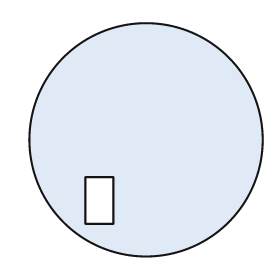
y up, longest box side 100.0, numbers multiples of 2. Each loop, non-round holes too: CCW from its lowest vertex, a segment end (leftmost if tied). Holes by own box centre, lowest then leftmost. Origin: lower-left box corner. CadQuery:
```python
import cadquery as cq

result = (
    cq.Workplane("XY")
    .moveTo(50.0, 50.0)
    .circle(50.0)
    .moveTo(24.0, 14.0)
    .lineTo(36.0, 14.0)
    .lineTo(36.0, 34.0)
    .lineTo(24.0, 34.0)
    .close()
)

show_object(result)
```